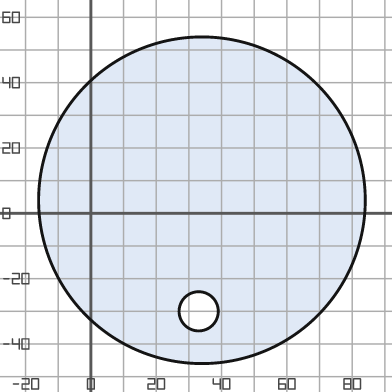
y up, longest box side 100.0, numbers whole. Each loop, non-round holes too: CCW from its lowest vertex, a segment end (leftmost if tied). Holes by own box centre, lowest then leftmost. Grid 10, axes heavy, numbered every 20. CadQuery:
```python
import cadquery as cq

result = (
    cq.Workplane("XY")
    .moveTo(34.0, 4.0)
    .circle(50.0)
    .moveTo(33.0, -30.0)
    .circle(6.0)
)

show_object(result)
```